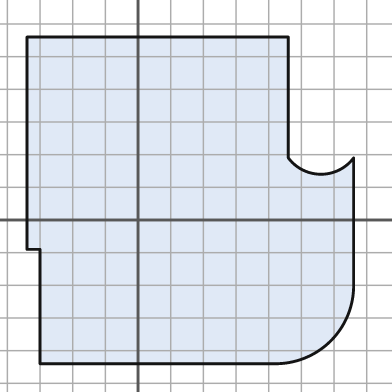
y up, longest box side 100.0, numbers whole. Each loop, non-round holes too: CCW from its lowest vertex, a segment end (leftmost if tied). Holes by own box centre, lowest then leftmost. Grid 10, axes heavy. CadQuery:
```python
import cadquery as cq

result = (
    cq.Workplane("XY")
    .moveTo(-30.0, -44.0)
    .lineTo(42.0, -44.0)
    .threePointArc((59.0, -37.0), (66.0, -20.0))
    .lineTo(66.0, 19.0)
    .threePointArc((56.0, 14.0), (46.0, 19.0))
    .lineTo(46.0, 56.0)
    .lineTo(-34.0, 56.0)
    .lineTo(-34.0, -9.0)
    .lineTo(-30.0, -9.0)
    .close()
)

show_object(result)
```